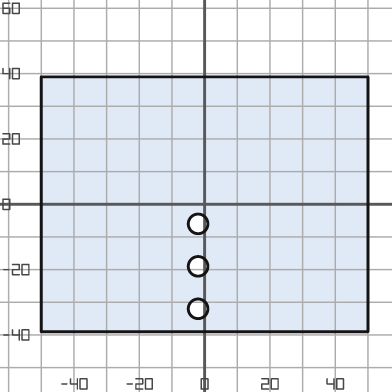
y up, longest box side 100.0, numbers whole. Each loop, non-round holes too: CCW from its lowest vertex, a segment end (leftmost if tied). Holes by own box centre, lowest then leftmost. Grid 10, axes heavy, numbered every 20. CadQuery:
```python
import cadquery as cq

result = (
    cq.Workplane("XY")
    .moveTo(-50.0, -39.0)
    .lineTo(50.0, -39.0)
    .lineTo(50.0, 39.0)
    .lineTo(-50.0, 39.0)
    .close()
    .moveTo(-2.0, -32.0)
    .circle(3.0)
    .moveTo(-2.0, -19.0)
    .circle(3.0)
    .moveTo(-2.0, -6.0)
    .circle(3.0)
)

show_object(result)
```